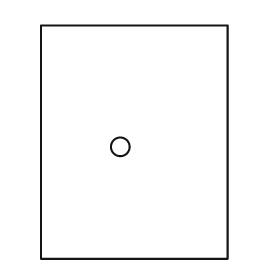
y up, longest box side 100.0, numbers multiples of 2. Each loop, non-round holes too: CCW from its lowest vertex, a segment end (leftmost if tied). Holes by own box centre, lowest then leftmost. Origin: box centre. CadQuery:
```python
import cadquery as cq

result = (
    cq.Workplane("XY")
    .moveTo(-40.0, -50.0)
    .lineTo(40.0, -50.0)
    .lineTo(40.0, 50.0)
    .lineTo(-40.0, 50.0)
    .close()
    .moveTo(-6.0, -2.0)
    .circle(4.0)
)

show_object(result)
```